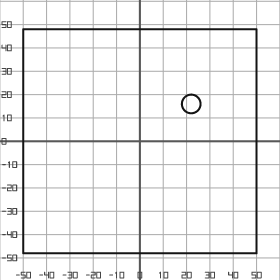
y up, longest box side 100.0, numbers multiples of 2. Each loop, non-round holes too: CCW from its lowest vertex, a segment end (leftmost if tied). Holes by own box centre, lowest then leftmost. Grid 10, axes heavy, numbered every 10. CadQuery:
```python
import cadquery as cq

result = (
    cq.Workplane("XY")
    .moveTo(-50.0, -48.0)
    .lineTo(50.0, -48.0)
    .lineTo(50.0, 48.0)
    .lineTo(-50.0, 48.0)
    .close()
    .moveTo(22.0, 16.0)
    .circle(4.0)
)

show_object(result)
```